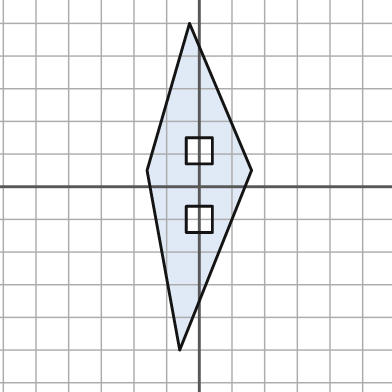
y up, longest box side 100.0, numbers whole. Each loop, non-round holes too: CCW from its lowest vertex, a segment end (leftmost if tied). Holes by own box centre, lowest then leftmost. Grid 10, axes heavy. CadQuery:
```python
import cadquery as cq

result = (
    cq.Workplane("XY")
    .moveTo(-6.0, -50.0)
    .lineTo(16.0, 5.0)
    .lineTo(-3.0, 50.0)
    .lineTo(-16.0, 5.0)
    .close()
    .moveTo(-4.0, -14.0)
    .lineTo(4.0, -14.0)
    .lineTo(4.0, -6.0)
    .lineTo(-4.0, -6.0)
    .close()
    .moveTo(-4.0, 7.0)
    .lineTo(4.0, 7.0)
    .lineTo(4.0, 15.0)
    .lineTo(-4.0, 15.0)
    .close()
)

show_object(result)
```